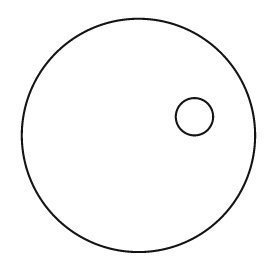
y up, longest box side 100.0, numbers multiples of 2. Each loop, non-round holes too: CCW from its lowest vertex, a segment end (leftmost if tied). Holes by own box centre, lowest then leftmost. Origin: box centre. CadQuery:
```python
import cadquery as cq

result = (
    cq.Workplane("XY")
    .moveTo(0.0, 0.0)
    .circle(50.0)
    .moveTo(24.0, 8.0)
    .circle(8.0)
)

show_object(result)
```